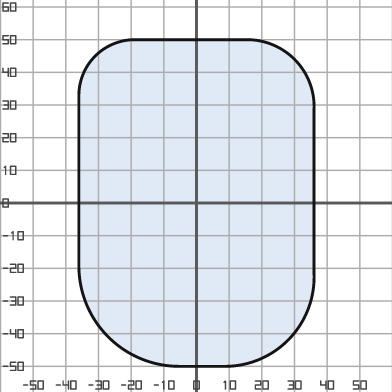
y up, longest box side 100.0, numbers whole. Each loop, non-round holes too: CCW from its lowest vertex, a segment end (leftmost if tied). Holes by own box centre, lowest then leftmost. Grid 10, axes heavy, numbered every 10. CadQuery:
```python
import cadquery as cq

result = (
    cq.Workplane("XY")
    .moveTo(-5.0, -50.0)
    .lineTo(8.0, -50.0)
    .threePointArc((28.0, -42.0), (36.0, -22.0))
    .lineTo(36.0, 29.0)
    .threePointArc((30.0, 44.0), (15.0, 50.0))
    .lineTo(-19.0, 50.0)
    .threePointArc((-31.0, 45.0), (-36.0, 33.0))
    .lineTo(-36.0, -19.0)
    .threePointArc((-27.0, -41.0), (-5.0, -50.0))
    .close()
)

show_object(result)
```